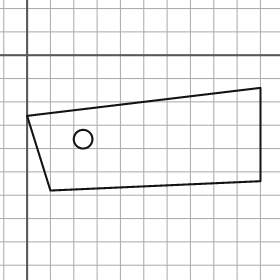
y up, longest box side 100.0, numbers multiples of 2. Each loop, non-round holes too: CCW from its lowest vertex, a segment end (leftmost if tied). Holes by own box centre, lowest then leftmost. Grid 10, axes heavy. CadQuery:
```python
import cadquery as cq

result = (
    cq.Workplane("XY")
    .moveTo(10.0, -58.0)
    .lineTo(100.0, -54.0)
    .lineTo(100.0, -14.0)
    .lineTo(0.0, -26.0)
    .close()
    .moveTo(24.0, -36.0)
    .circle(4.0)
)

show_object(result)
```